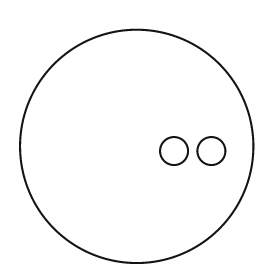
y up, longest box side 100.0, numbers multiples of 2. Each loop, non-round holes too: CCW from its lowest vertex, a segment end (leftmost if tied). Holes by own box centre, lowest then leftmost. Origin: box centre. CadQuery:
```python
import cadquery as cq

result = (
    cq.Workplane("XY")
    .moveTo(0.0, 0.0)
    .circle(50.0)
    .moveTo(16.0, -2.0)
    .circle(6.0)
    .moveTo(32.0, -2.0)
    .circle(6.0)
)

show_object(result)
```